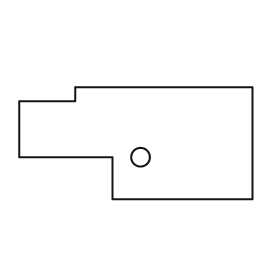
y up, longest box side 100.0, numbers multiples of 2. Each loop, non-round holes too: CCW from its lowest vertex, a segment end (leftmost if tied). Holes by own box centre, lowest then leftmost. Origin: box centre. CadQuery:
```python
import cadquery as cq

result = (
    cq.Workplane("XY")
    .moveTo(-10.0, -24.0)
    .lineTo(50.0, -24.0)
    .lineTo(50.0, 24.0)
    .lineTo(-26.0, 24.0)
    .lineTo(-26.0, 18.0)
    .lineTo(-50.0, 18.0)
    .lineTo(-50.0, -6.0)
    .lineTo(-10.0, -6.0)
    .close()
    .moveTo(2.0, -6.0)
    .circle(4.0)
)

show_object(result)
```